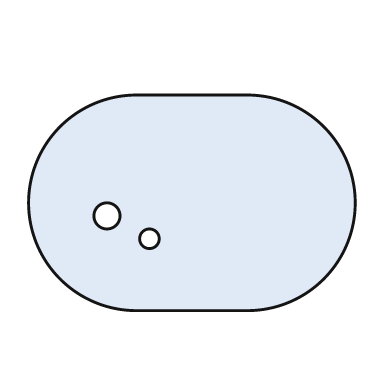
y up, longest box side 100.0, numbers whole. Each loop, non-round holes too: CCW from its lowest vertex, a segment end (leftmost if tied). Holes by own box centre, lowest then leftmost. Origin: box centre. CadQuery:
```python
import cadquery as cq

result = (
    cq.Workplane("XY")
    .moveTo(-17.0, -33.0)
    .lineTo(17.0, -33.0)
    .threePointArc((50.0, 0.0), (17.0, 33.0))
    .lineTo(-17.0, 33.0)
    .threePointArc((-50.0, 0.0), (-17.0, -33.0))
    .close()
    .moveTo(-13.0, -11.0)
    .circle(3.0)
    .moveTo(-26.0, -4.0)
    .circle(4.0)
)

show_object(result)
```